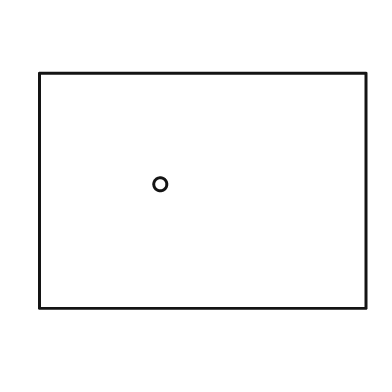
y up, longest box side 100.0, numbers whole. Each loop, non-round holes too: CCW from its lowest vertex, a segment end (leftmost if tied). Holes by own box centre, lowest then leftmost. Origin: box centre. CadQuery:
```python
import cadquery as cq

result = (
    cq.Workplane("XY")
    .moveTo(-50.0, -36.0)
    .lineTo(50.0, -36.0)
    .lineTo(50.0, 36.0)
    .lineTo(-50.0, 36.0)
    .close()
    .moveTo(-13.0, 2.0)
    .circle(2.0)
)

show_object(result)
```